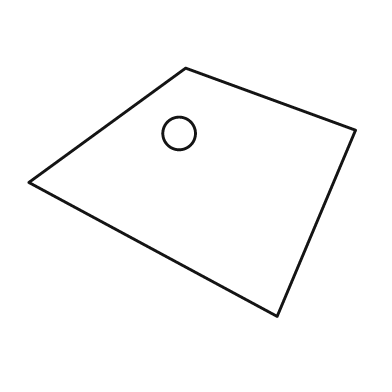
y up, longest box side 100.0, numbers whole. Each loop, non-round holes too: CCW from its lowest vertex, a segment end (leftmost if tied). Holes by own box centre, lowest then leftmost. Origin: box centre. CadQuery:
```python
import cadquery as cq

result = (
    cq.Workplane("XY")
    .moveTo(26.0, -38.0)
    .lineTo(50.0, 19.0)
    .lineTo(-2.0, 38.0)
    .lineTo(-50.0, 3.0)
    .close()
    .moveTo(-4.0, 18.0)
    .circle(5.0)
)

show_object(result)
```